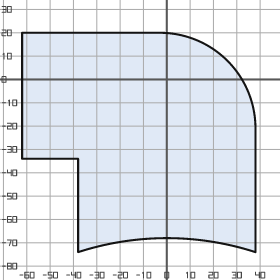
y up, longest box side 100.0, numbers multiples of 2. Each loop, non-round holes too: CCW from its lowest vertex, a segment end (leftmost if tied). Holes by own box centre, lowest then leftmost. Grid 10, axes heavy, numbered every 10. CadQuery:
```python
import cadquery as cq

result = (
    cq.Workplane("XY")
    .moveTo(-38.0, -74.0)
    .threePointArc((0.0, -68.0), (38.0, -74.0))
    .lineTo(38.0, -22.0)
    .threePointArc((26.0, 8.0), (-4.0, 20.0))
    .lineTo(-62.0, 20.0)
    .lineTo(-62.0, -34.0)
    .lineTo(-38.0, -34.0)
    .close()
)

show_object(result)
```